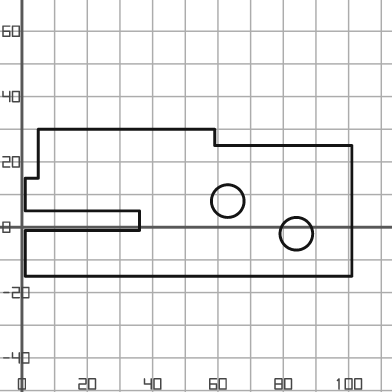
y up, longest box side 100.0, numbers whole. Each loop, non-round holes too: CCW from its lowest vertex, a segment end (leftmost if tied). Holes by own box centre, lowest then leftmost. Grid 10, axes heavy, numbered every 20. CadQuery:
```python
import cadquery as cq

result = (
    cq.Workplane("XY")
    .moveTo(1.0, -15.0)
    .lineTo(101.0, -15.0)
    .lineTo(101.0, 25.0)
    .lineTo(59.0, 25.0)
    .lineTo(59.0, 30.0)
    .lineTo(5.0, 30.0)
    .lineTo(5.0, 15.0)
    .lineTo(1.0, 15.0)
    .lineTo(1.0, 5.0)
    .lineTo(36.0, 5.0)
    .lineTo(36.0, -1.0)
    .lineTo(1.0, -1.0)
    .close()
    .moveTo(84.0, -2.0)
    .circle(5.0)
    .moveTo(63.0, 8.0)
    .circle(5.0)
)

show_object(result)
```